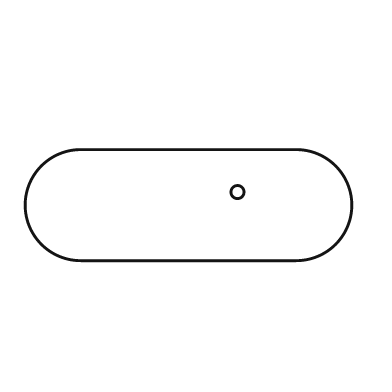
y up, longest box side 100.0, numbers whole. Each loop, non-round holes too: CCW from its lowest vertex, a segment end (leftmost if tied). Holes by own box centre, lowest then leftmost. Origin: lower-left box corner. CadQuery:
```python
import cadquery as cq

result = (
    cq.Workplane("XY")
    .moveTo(17.0, 0.0)
    .lineTo(83.0, 0.0)
    .threePointArc((100.0, 17.0), (83.0, 34.0))
    .lineTo(17.0, 34.0)
    .threePointArc((0.0, 17.0), (17.0, 0.0))
    .close()
    .moveTo(65.0, 21.0)
    .circle(2.0)
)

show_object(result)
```